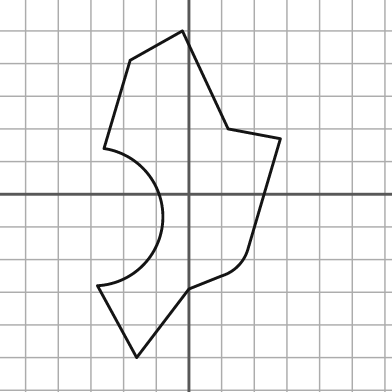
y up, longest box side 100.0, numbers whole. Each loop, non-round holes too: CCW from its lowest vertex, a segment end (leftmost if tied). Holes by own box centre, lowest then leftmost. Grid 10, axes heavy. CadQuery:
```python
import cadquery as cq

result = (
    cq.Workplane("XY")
    .moveTo(-16.0, -50.0)
    .lineTo(0.0, -29.0)
    .lineTo(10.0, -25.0)
    .threePointArc((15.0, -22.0), (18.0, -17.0))
    .lineTo(28.0, 17.0)
    .lineTo(12.0, 20.0)
    .lineTo(-2.0, 50.0)
    .lineTo(-18.0, 41.0)
    .lineTo(-26.0, 14.0)
    .threePointArc((-8.0, -8.0), (-28.0, -28.0))
    .close()
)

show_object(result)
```